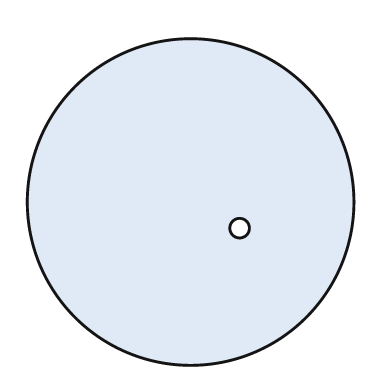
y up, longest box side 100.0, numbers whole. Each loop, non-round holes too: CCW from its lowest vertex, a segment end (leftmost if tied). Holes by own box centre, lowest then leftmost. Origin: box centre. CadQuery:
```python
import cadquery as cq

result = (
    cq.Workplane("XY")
    .moveTo(0.0, 0.0)
    .circle(50.0)
    .moveTo(15.0, -8.0)
    .circle(3.0)
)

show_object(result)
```